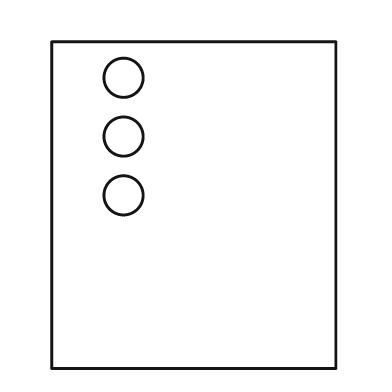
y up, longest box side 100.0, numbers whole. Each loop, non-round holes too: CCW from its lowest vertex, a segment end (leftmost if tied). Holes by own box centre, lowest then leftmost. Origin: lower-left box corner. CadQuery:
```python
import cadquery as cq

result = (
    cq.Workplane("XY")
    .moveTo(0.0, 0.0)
    .lineTo(87.0, 0.0)
    .lineTo(87.0, 100.0)
    .lineTo(0.0, 100.0)
    .close()
    .moveTo(22.0, 53.0)
    .circle(6.0)
    .moveTo(22.0, 71.0)
    .circle(6.0)
    .moveTo(22.0, 89.0)
    .circle(6.0)
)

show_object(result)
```